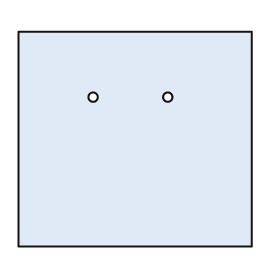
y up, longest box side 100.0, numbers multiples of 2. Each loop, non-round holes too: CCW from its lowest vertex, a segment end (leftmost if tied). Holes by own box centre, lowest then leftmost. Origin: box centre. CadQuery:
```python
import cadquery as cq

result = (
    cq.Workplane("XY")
    .moveTo(-50.0, -46.0)
    .lineTo(50.0, -46.0)
    .lineTo(50.0, 46.0)
    .lineTo(-50.0, 46.0)
    .close()
    .moveTo(-18.0, 18.0)
    .circle(2.0)
    .moveTo(14.0, 18.0)
    .circle(2.0)
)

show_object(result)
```